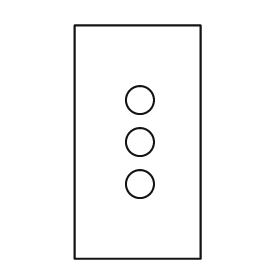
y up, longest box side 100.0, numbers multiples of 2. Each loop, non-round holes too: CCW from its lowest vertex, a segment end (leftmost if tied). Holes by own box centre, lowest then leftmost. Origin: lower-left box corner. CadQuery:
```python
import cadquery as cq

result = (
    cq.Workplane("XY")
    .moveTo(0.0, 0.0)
    .lineTo(54.0, 0.0)
    .lineTo(54.0, 100.0)
    .lineTo(0.0, 100.0)
    .close()
    .moveTo(28.0, 32.0)
    .circle(6.0)
    .moveTo(28.0, 50.0)
    .circle(6.0)
    .moveTo(28.0, 68.0)
    .circle(6.0)
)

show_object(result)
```